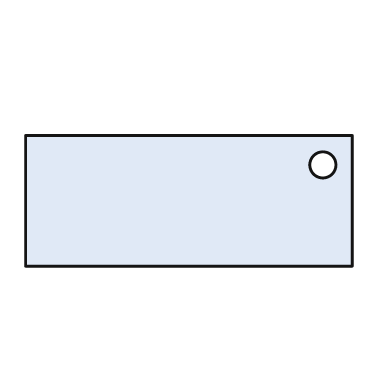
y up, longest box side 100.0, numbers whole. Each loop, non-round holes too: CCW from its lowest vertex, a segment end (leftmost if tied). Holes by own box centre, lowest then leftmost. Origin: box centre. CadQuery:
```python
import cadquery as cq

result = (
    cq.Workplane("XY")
    .moveTo(-50.0, -20.0)
    .lineTo(50.0, -20.0)
    .lineTo(50.0, 20.0)
    .lineTo(-50.0, 20.0)
    .close()
    .moveTo(41.0, 11.0)
    .circle(4.0)
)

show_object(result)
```